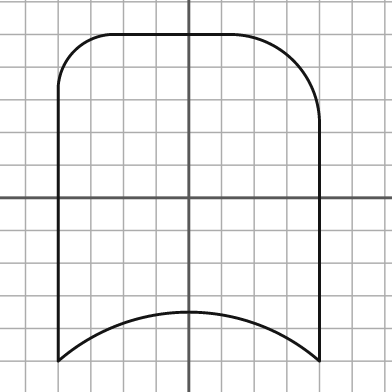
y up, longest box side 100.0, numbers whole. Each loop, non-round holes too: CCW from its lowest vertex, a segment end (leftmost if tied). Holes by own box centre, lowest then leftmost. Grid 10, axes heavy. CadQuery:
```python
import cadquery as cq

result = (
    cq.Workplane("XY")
    .moveTo(-40.0, -50.0)
    .threePointArc((0.0, -35.0), (40.0, -50.0))
    .lineTo(40.0, 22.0)
    .threePointArc((32.0, 42.0), (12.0, 50.0))
    .lineTo(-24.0, 50.0)
    .threePointArc((-35.0, 45.0), (-40.0, 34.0))
    .close()
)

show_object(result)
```